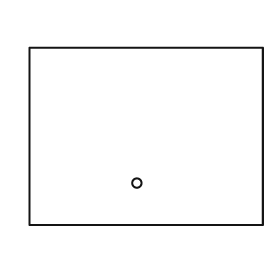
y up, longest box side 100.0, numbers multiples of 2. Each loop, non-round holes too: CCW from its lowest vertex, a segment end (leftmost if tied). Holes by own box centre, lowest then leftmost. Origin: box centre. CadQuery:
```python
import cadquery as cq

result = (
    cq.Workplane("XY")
    .moveTo(-50.0, -38.0)
    .lineTo(50.0, -38.0)
    .lineTo(50.0, 38.0)
    .lineTo(-50.0, 38.0)
    .close()
    .moveTo(-4.0, -20.0)
    .circle(2.0)
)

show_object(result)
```